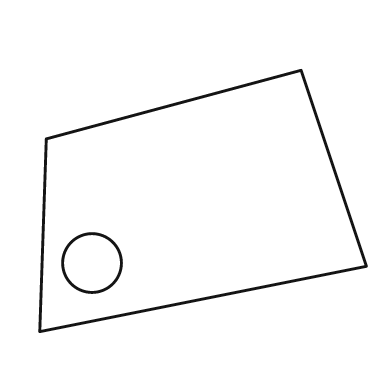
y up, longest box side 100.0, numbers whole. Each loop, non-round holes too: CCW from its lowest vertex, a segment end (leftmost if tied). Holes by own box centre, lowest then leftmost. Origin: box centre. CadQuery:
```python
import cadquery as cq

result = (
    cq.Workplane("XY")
    .moveTo(-50.0, -40.0)
    .lineTo(50.0, -20.0)
    .lineTo(30.0, 40.0)
    .lineTo(-48.0, 19.0)
    .close()
    .moveTo(-34.0, -19.0)
    .circle(9.0)
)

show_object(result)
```